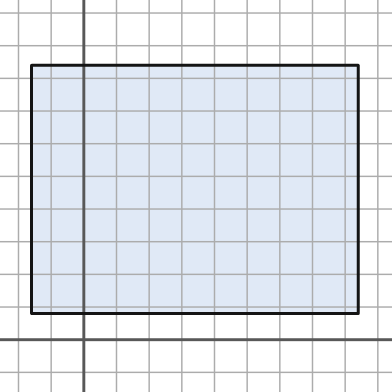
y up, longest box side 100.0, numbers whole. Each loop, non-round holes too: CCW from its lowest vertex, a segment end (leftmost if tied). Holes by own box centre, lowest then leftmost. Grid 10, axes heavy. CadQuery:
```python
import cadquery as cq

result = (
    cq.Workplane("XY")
    .moveTo(-16.0, 8.0)
    .lineTo(84.0, 8.0)
    .lineTo(84.0, 84.0)
    .lineTo(-16.0, 84.0)
    .close()
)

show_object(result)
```